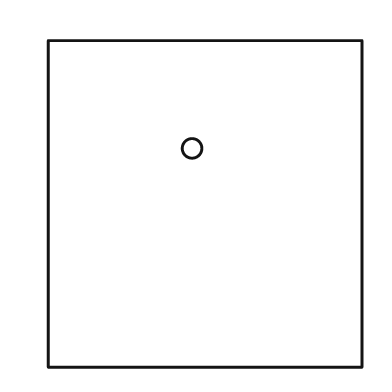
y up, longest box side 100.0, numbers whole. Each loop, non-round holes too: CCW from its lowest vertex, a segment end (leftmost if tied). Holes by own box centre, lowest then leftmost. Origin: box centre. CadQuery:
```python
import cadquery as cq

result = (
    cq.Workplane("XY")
    .moveTo(-48.0, -50.0)
    .lineTo(48.0, -50.0)
    .lineTo(48.0, 50.0)
    .lineTo(-48.0, 50.0)
    .close()
    .moveTo(-4.0, 17.0)
    .circle(3.0)
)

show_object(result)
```